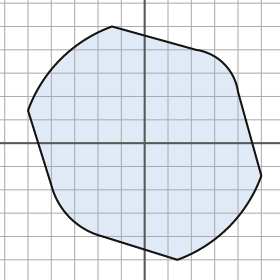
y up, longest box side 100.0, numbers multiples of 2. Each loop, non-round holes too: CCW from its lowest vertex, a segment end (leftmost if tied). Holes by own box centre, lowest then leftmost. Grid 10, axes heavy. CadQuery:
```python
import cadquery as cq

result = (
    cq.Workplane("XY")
    .moveTo(14.0, -50.0)
    .threePointArc((36.0, -36.0), (50.0, -14.0))
    .lineTo(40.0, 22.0)
    .threePointArc((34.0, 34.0), (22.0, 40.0))
    .lineTo(-14.0, 50.0)
    .threePointArc((-36.0, 36.0), (-50.0, 14.0))
    .lineTo(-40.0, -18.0)
    .threePointArc((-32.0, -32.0), (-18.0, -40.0))
    .close()
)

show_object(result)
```